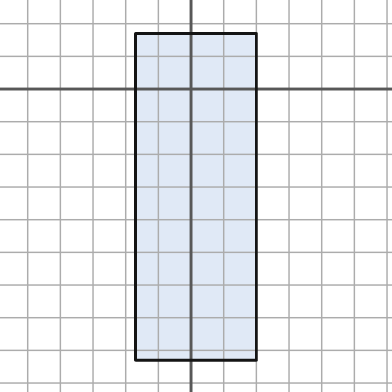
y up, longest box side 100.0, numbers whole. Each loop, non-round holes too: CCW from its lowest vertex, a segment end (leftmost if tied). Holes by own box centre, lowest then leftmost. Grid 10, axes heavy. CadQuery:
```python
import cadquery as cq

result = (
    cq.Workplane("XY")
    .moveTo(-17.0, -83.0)
    .lineTo(20.0, -83.0)
    .lineTo(20.0, 17.0)
    .lineTo(-17.0, 17.0)
    .close()
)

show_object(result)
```